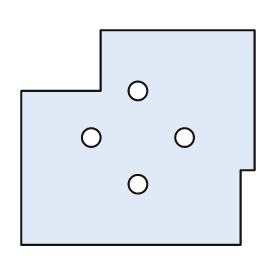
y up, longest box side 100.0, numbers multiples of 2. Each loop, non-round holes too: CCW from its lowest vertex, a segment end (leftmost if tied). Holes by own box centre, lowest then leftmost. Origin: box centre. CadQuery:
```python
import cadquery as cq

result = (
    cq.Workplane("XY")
    .moveTo(-50.0, -46.0)
    .lineTo(44.0, -46.0)
    .lineTo(44.0, -14.0)
    .lineTo(50.0, -14.0)
    .lineTo(50.0, 46.0)
    .lineTo(-16.0, 46.0)
    .lineTo(-16.0, 20.0)
    .lineTo(-50.0, 20.0)
    .close()
    .moveTo(0.0, -20.0)
    .circle(4.0)
    .moveTo(-20.0, 0.0)
    .circle(4.0)
    .moveTo(20.0, 0.0)
    .circle(4.0)
    .moveTo(0.0, 20.0)
    .circle(4.0)
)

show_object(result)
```